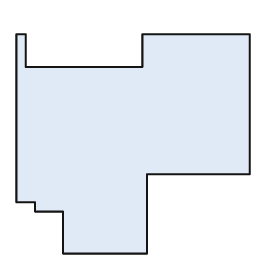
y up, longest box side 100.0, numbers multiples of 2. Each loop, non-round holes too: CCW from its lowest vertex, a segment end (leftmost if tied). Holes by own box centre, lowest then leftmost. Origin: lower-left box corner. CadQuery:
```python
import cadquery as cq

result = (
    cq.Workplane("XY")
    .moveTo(20.0, 0.0)
    .lineTo(56.0, 0.0)
    .lineTo(56.0, 34.0)
    .lineTo(100.0, 34.0)
    .lineTo(100.0, 94.0)
    .lineTo(54.0, 94.0)
    .lineTo(54.0, 80.0)
    .lineTo(4.0, 80.0)
    .lineTo(4.0, 94.0)
    .lineTo(0.0, 94.0)
    .lineTo(0.0, 22.0)
    .lineTo(8.0, 22.0)
    .lineTo(8.0, 18.0)
    .lineTo(20.0, 18.0)
    .close()
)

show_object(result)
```